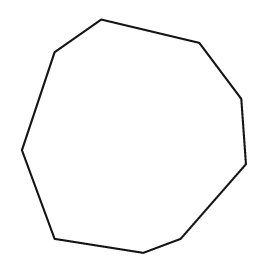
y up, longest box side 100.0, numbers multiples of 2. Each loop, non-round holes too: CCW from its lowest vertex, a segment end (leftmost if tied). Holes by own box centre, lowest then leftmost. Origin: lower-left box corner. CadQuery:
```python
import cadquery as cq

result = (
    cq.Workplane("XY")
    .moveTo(52.0, 0.0)
    .lineTo(68.0, 6.0)
    .lineTo(96.0, 38.0)
    .lineTo(94.0, 66.0)
    .lineTo(76.0, 90.0)
    .lineTo(34.0, 100.0)
    .lineTo(14.0, 86.0)
    .lineTo(0.0, 44.0)
    .lineTo(14.0, 6.0)
    .close()
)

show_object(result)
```